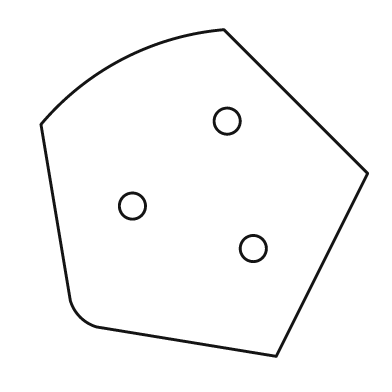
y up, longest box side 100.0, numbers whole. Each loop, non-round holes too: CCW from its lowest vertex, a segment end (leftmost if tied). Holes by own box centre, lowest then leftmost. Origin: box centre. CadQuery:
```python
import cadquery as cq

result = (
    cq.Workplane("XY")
    .moveTo(22.0, -50.0)
    .lineTo(50.0, 6.0)
    .lineTo(6.0, 50.0)
    .threePointArc((-25.0, 41.0), (-50.0, 21.0))
    .lineTo(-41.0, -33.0)
    .threePointArc((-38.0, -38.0), (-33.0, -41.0))
    .close()
    .moveTo(15.0, -17.0)
    .circle(4.0)
    .moveTo(-22.0, -4.0)
    .circle(4.0)
    .moveTo(7.0, 22.0)
    .circle(4.0)
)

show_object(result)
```